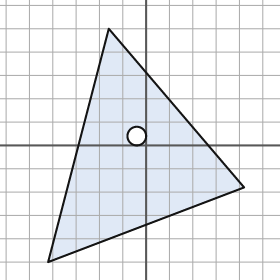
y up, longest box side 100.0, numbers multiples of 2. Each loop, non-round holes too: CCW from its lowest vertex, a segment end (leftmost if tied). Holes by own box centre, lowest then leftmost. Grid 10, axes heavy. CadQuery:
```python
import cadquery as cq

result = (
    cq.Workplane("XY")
    .moveTo(-42.0, -50.0)
    .lineTo(42.0, -18.0)
    .lineTo(-16.0, 50.0)
    .close()
    .moveTo(-4.0, 4.0)
    .circle(4.0)
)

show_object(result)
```